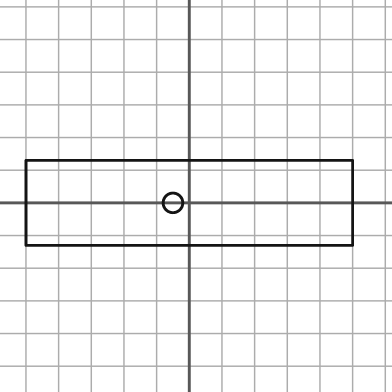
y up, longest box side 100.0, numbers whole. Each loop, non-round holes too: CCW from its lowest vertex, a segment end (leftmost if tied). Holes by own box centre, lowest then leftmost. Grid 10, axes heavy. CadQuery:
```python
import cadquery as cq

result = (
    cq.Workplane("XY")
    .moveTo(-50.0, -13.0)
    .lineTo(50.0, -13.0)
    .lineTo(50.0, 13.0)
    .lineTo(-50.0, 13.0)
    .close()
    .moveTo(-5.0, 0.0)
    .circle(3.0)
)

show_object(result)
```